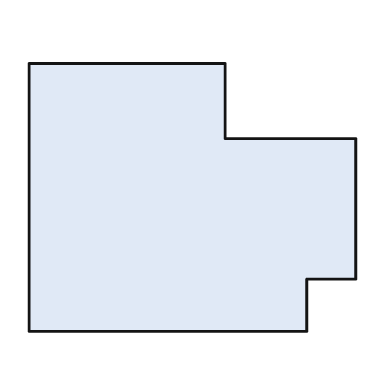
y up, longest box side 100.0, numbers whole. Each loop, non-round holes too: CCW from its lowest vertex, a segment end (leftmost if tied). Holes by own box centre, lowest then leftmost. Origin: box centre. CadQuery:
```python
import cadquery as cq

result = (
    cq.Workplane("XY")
    .moveTo(-50.0, -41.0)
    .lineTo(35.0, -41.0)
    .lineTo(35.0, -25.0)
    .lineTo(50.0, -25.0)
    .lineTo(50.0, 18.0)
    .lineTo(10.0, 18.0)
    .lineTo(10.0, 41.0)
    .lineTo(-50.0, 41.0)
    .close()
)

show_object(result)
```